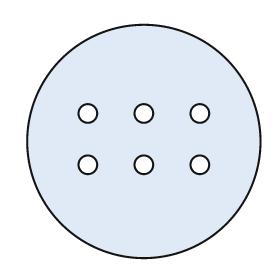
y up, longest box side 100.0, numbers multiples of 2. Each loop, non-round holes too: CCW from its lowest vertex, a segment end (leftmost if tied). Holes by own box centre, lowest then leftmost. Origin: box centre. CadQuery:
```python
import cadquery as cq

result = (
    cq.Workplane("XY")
    .moveTo(0.0, 0.0)
    .circle(50.0)
    .moveTo(-24.0, -10.0)
    .circle(4.0)
    .moveTo(0.0, -10.0)
    .circle(4.0)
    .moveTo(24.0, -10.0)
    .circle(4.0)
    .moveTo(-24.0, 12.0)
    .circle(4.0)
    .moveTo(0.0, 12.0)
    .circle(4.0)
    .moveTo(24.0, 12.0)
    .circle(4.0)
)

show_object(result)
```